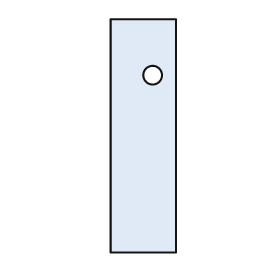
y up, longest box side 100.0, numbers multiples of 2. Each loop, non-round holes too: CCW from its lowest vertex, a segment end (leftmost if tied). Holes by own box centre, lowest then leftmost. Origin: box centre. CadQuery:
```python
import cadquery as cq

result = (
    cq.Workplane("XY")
    .moveTo(-14.0, -50.0)
    .lineTo(14.0, -50.0)
    .lineTo(14.0, 50.0)
    .lineTo(-14.0, 50.0)
    .close()
    .moveTo(4.0, 26.0)
    .circle(4.0)
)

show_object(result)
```